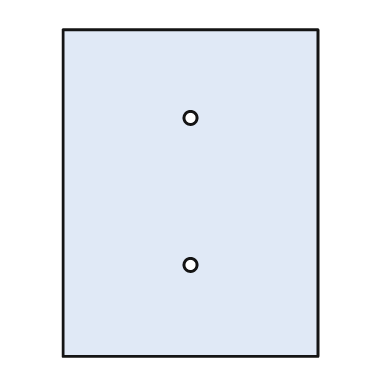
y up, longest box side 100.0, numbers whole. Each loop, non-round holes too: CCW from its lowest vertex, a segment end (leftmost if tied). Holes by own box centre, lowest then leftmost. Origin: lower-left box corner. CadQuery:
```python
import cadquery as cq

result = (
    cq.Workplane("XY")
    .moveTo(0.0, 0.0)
    .lineTo(78.0, 0.0)
    .lineTo(78.0, 100.0)
    .lineTo(0.0, 100.0)
    .close()
    .moveTo(39.0, 28.0)
    .circle(2.0)
    .moveTo(39.0, 73.0)
    .circle(2.0)
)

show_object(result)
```